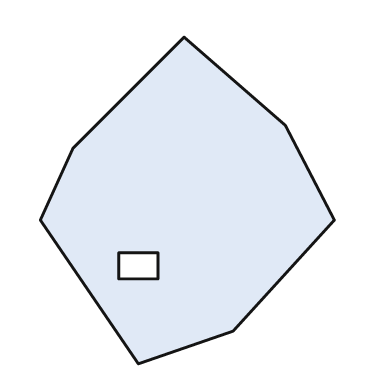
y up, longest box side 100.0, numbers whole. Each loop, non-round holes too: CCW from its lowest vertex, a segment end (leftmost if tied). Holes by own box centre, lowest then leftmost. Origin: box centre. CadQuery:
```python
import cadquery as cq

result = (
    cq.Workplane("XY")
    .moveTo(-15.0, -50.0)
    .lineTo(14.0, -40.0)
    .lineTo(45.0, -6.0)
    .lineTo(30.0, 23.0)
    .lineTo(-1.0, 50.0)
    .lineTo(-35.0, 16.0)
    .lineTo(-45.0, -6.0)
    .close()
    .moveTo(-21.0, -24.0)
    .lineTo(-9.0, -24.0)
    .lineTo(-9.0, -16.0)
    .lineTo(-21.0, -16.0)
    .close()
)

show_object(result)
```